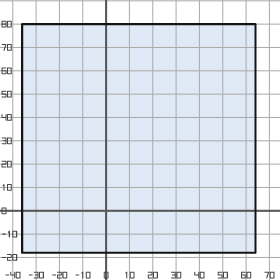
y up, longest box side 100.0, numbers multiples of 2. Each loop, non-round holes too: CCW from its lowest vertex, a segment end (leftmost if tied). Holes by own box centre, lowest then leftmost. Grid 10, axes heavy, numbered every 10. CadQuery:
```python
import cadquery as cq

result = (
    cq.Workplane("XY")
    .moveTo(-36.0, -18.0)
    .lineTo(64.0, -18.0)
    .lineTo(64.0, 80.0)
    .lineTo(-36.0, 80.0)
    .close()
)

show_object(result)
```